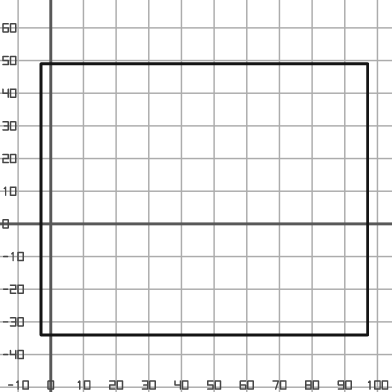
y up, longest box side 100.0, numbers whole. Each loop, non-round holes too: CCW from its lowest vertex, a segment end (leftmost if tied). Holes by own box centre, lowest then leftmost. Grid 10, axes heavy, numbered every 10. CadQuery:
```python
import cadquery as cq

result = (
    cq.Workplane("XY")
    .moveTo(-3.0, -34.0)
    .lineTo(97.0, -34.0)
    .lineTo(97.0, 49.0)
    .lineTo(-3.0, 49.0)
    .close()
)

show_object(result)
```